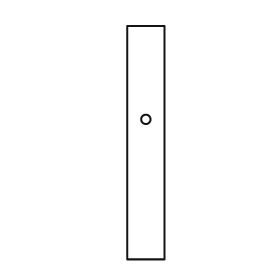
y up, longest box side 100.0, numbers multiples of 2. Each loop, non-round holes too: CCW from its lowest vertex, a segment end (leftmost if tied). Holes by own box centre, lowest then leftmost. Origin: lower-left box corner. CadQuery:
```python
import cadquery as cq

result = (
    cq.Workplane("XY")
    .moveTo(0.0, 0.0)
    .lineTo(16.0, 0.0)
    .lineTo(16.0, 100.0)
    .lineTo(0.0, 100.0)
    .close()
    .moveTo(8.0, 60.0)
    .circle(2.0)
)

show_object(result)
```